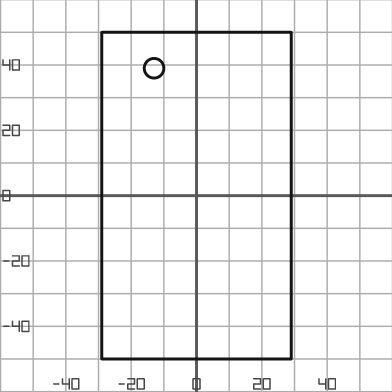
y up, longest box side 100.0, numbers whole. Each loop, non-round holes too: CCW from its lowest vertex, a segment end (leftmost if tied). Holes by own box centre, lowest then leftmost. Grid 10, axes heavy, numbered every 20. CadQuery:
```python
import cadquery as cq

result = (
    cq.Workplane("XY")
    .moveTo(-29.0, -50.0)
    .lineTo(29.0, -50.0)
    .lineTo(29.0, 50.0)
    .lineTo(-29.0, 50.0)
    .close()
    .moveTo(-13.0, 39.0)
    .circle(3.0)
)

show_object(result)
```